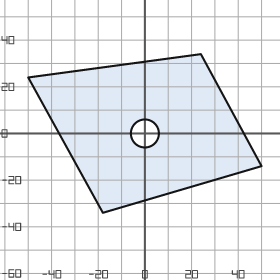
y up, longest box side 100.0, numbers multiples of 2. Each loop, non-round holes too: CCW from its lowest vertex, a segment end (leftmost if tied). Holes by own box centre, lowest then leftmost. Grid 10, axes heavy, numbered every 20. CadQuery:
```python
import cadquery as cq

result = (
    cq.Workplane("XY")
    .moveTo(-18.0, -34.0)
    .lineTo(50.0, -14.0)
    .lineTo(24.0, 34.0)
    .lineTo(-50.0, 24.0)
    .close()
    .moveTo(0.0, 0.0)
    .circle(6.0)
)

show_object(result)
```